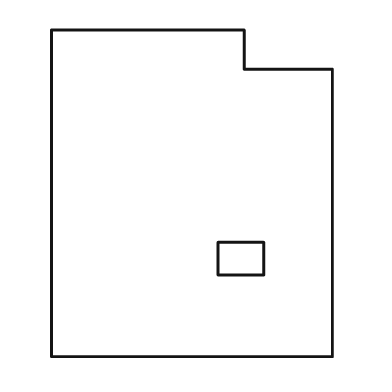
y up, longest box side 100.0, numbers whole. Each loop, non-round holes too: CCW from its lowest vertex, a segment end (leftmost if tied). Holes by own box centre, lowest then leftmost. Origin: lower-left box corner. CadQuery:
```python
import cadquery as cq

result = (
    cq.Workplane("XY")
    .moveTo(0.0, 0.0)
    .lineTo(86.0, 0.0)
    .lineTo(86.0, 88.0)
    .lineTo(59.0, 88.0)
    .lineTo(59.0, 100.0)
    .lineTo(0.0, 100.0)
    .close()
    .moveTo(51.0, 25.0)
    .lineTo(65.0, 25.0)
    .lineTo(65.0, 35.0)
    .lineTo(51.0, 35.0)
    .close()
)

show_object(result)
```